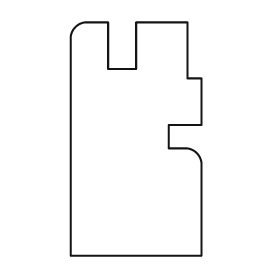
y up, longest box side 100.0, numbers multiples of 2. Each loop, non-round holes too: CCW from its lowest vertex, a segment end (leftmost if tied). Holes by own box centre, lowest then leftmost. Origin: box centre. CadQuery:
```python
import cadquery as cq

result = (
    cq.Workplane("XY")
    .moveTo(-28.0, -50.0)
    .lineTo(28.0, -50.0)
    .lineTo(28.0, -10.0)
    .threePointArc((26.0, -6.0), (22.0, -4.0))
    .lineTo(14.0, -4.0)
    .lineTo(14.0, 6.0)
    .lineTo(28.0, 6.0)
    .lineTo(28.0, 26.0)
    .lineTo(22.0, 26.0)
    .lineTo(22.0, 50.0)
    .lineTo(0.0, 50.0)
    .lineTo(0.0, 30.0)
    .lineTo(-12.0, 30.0)
    .lineTo(-12.0, 50.0)
    .lineTo(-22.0, 50.0)
    .threePointArc((-26.0, 48.0), (-28.0, 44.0))
    .close()
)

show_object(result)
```